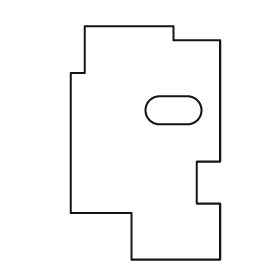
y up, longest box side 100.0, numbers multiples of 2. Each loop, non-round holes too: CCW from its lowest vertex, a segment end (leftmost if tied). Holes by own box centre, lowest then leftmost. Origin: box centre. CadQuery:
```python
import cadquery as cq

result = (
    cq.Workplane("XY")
    .moveTo(-6.0, -50.0)
    .lineTo(32.0, -50.0)
    .lineTo(32.0, -26.0)
    .lineTo(22.0, -26.0)
    .lineTo(22.0, -8.0)
    .lineTo(32.0, -8.0)
    .lineTo(32.0, 44.0)
    .lineTo(12.0, 44.0)
    .lineTo(12.0, 50.0)
    .lineTo(-26.0, 50.0)
    .lineTo(-26.0, 30.0)
    .lineTo(-32.0, 30.0)
    .lineTo(-32.0, -30.0)
    .lineTo(-6.0, -30.0)
    .close()
    .moveTo(6.0, 8.0)
    .lineTo(18.0, 8.0)
    .threePointArc((24.0, 14.0), (18.0, 20.0))
    .lineTo(6.0, 20.0)
    .threePointArc((0.0, 14.0), (6.0, 8.0))
    .close()
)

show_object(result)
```